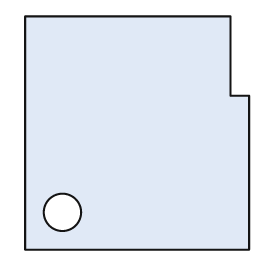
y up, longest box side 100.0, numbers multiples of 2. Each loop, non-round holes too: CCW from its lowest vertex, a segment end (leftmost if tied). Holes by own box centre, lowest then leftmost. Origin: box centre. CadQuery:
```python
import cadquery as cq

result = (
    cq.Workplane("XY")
    .moveTo(-48.0, -50.0)
    .lineTo(48.0, -50.0)
    .lineTo(48.0, 16.0)
    .lineTo(40.0, 16.0)
    .lineTo(40.0, 50.0)
    .lineTo(-48.0, 50.0)
    .close()
    .moveTo(-32.0, -34.0)
    .circle(8.0)
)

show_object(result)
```